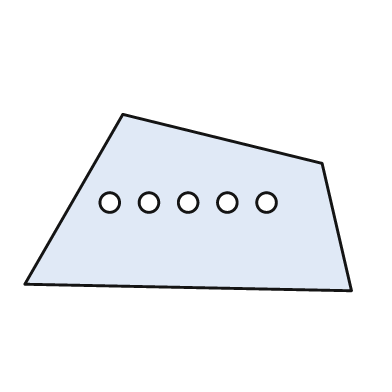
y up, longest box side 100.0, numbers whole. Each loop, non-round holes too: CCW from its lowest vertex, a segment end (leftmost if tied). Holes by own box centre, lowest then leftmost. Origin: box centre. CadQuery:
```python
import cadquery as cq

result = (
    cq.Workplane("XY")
    .moveTo(50.0, -27.0)
    .lineTo(41.0, 12.0)
    .lineTo(-20.0, 27.0)
    .lineTo(-50.0, -25.0)
    .close()
    .moveTo(-24.0, 0.0)
    .circle(3.0)
    .moveTo(-12.0, 0.0)
    .circle(3.0)
    .moveTo(0.0, 0.0)
    .circle(3.0)
    .moveTo(12.0, 0.0)
    .circle(3.0)
    .moveTo(24.0, 0.0)
    .circle(3.0)
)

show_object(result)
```